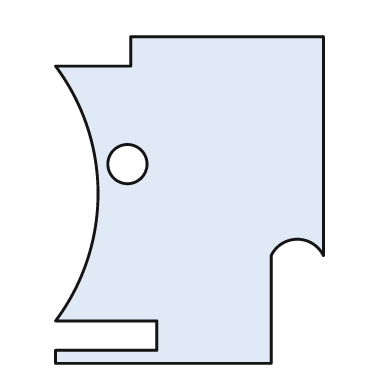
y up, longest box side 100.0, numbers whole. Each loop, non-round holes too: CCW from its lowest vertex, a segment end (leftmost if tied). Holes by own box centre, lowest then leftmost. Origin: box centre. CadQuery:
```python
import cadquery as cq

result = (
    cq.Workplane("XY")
    .moveTo(-41.0, -50.0)
    .lineTo(25.0, -50.0)
    .lineTo(25.0, -17.0)
    .threePointArc((33.0, -12.0), (41.0, -17.0))
    .lineTo(41.0, 50.0)
    .lineTo(-18.0, 50.0)
    .lineTo(-18.0, 41.0)
    .lineTo(-41.0, 41.0)
    .threePointArc((-28.0, 2.0), (-41.0, -37.0))
    .lineTo(-10.0, -37.0)
    .lineTo(-10.0, -46.0)
    .lineTo(-41.0, -46.0)
    .close()
    .moveTo(-19.0, 11.0)
    .circle(6.0)
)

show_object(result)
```